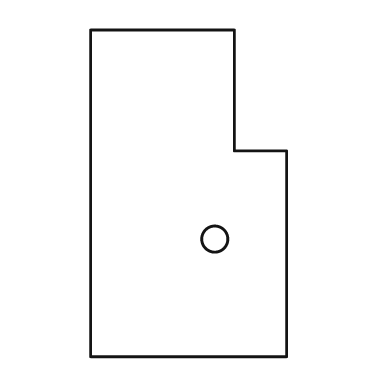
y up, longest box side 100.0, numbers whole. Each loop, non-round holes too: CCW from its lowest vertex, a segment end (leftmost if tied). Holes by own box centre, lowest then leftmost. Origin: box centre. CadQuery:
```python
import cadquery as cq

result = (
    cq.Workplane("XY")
    .moveTo(-30.0, -50.0)
    .lineTo(30.0, -50.0)
    .lineTo(30.0, 13.0)
    .lineTo(14.0, 13.0)
    .lineTo(14.0, 50.0)
    .lineTo(-30.0, 50.0)
    .close()
    .moveTo(8.0, -14.0)
    .circle(4.0)
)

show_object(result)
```